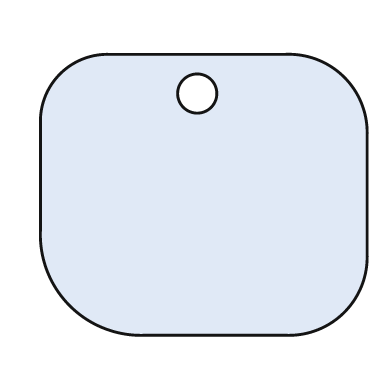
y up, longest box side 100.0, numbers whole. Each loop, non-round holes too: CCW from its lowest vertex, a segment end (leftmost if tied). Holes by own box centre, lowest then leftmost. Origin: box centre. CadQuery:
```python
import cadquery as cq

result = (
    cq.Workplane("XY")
    .moveTo(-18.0, -43.0)
    .lineTo(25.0, -43.0)
    .threePointArc((43.0, -36.0), (50.0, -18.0))
    .lineTo(50.0, 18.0)
    .threePointArc((43.0, 36.0), (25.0, 43.0))
    .lineTo(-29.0, 43.0)
    .threePointArc((-44.0, 37.0), (-50.0, 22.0))
    .lineTo(-50.0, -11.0)
    .threePointArc((-41.0, -34.0), (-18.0, -43.0))
    .close()
    .moveTo(-2.0, 31.0)
    .circle(6.0)
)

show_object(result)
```